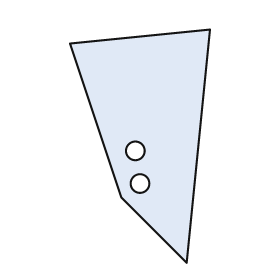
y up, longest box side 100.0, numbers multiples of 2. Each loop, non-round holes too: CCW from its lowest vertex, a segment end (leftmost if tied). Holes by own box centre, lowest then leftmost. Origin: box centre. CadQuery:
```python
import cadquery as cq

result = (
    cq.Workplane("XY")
    .moveTo(20.0, -50.0)
    .lineTo(30.0, 50.0)
    .lineTo(-30.0, 44.0)
    .lineTo(-8.0, -22.0)
    .close()
    .moveTo(0.0, -16.0)
    .circle(4.0)
    .moveTo(-2.0, -2.0)
    .circle(4.0)
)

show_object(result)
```